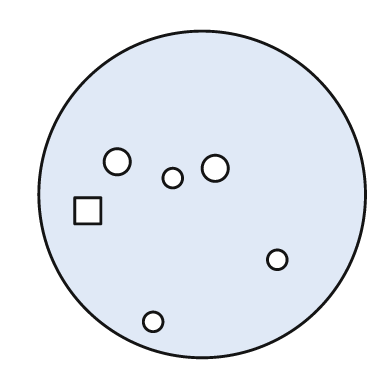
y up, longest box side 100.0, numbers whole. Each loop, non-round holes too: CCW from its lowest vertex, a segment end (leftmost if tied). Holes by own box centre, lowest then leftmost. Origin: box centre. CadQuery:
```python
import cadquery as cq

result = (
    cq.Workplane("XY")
    .moveTo(0.0, 0.0)
    .circle(50.0)
    .moveTo(-15.0, -39.0)
    .circle(3.0)
    .moveTo(23.0, -20.0)
    .circle(3.0)
    .moveTo(-39.0, -9.0)
    .lineTo(-31.0, -9.0)
    .lineTo(-31.0, -1.0)
    .lineTo(-39.0, -1.0)
    .close()
    .moveTo(-9.0, 5.0)
    .circle(3.0)
    .moveTo(4.0, 8.0)
    .circle(4.0)
    .moveTo(-26.0, 10.0)
    .circle(4.0)
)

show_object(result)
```